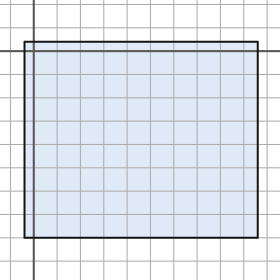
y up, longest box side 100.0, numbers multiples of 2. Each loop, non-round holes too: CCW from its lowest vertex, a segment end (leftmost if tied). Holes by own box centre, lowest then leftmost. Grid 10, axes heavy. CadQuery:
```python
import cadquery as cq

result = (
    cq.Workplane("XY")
    .moveTo(-4.0, -80.0)
    .lineTo(96.0, -80.0)
    .lineTo(96.0, 4.0)
    .lineTo(-4.0, 4.0)
    .close()
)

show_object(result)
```